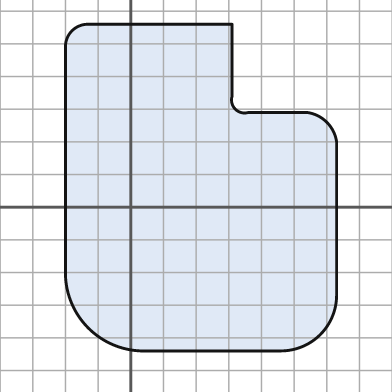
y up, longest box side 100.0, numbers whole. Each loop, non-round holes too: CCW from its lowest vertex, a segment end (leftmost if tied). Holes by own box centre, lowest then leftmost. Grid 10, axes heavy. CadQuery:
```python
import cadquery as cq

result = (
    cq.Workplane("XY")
    .moveTo(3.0, -44.0)
    .lineTo(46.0, -44.0)
    .threePointArc((58.0, -39.0), (63.0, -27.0))
    .lineTo(63.0, 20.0)
    .threePointArc((60.0, 26.0), (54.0, 29.0))
    .lineTo(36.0, 29.0)
    .threePointArc((32.0, 30.0), (31.0, 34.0))
    .lineTo(31.0, 56.0)
    .lineTo(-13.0, 56.0)
    .threePointArc((-18.0, 54.0), (-20.0, 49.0))
    .lineTo(-20.0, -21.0)
    .threePointArc((-13.0, -37.0), (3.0, -44.0))
    .close()
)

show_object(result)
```